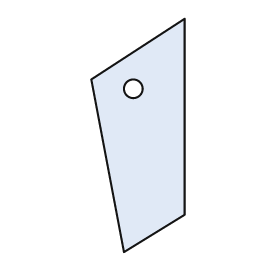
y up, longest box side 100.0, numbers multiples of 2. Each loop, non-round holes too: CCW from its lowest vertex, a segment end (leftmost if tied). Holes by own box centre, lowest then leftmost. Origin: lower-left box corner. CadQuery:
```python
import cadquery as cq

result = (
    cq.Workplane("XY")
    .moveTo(14.0, 0.0)
    .lineTo(40.0, 16.0)
    .lineTo(40.0, 100.0)
    .lineTo(0.0, 74.0)
    .close()
    .moveTo(18.0, 70.0)
    .circle(4.0)
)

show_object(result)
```